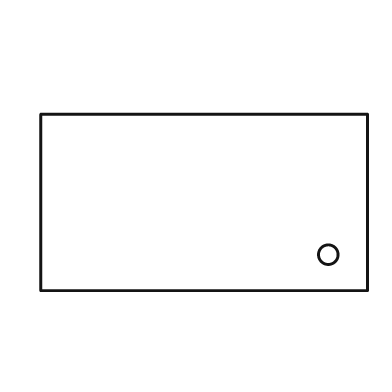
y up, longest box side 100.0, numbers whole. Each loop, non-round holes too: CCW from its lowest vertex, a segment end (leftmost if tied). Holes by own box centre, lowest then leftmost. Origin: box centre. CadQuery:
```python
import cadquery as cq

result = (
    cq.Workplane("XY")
    .moveTo(-50.0, -27.0)
    .lineTo(50.0, -27.0)
    .lineTo(50.0, 27.0)
    .lineTo(-50.0, 27.0)
    .close()
    .moveTo(38.0, -16.0)
    .circle(3.0)
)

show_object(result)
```